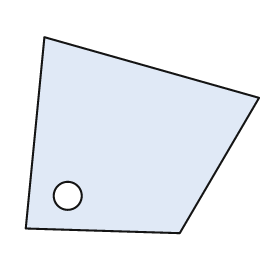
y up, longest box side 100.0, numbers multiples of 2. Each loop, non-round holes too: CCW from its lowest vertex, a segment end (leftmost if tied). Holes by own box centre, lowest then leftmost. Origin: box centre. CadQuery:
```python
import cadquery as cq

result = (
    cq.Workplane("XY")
    .moveTo(16.0, -42.0)
    .lineTo(50.0, 16.0)
    .lineTo(-42.0, 42.0)
    .lineTo(-50.0, -40.0)
    .close()
    .moveTo(-32.0, -26.0)
    .circle(6.0)
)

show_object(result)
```